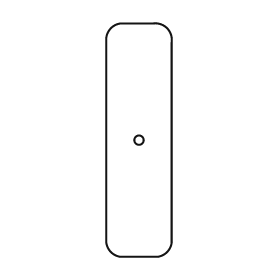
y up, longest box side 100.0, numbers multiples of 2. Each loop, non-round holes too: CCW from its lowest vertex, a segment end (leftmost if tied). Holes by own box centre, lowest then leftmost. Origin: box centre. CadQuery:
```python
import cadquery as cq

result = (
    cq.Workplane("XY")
    .moveTo(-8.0, -50.0)
    .lineTo(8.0, -50.0)
    .threePointArc((12.0, -48.0), (14.0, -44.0))
    .lineTo(14.0, 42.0)
    .threePointArc((12.0, 48.0), (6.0, 50.0))
    .lineTo(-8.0, 50.0)
    .threePointArc((-12.0, 48.0), (-14.0, 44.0))
    .lineTo(-14.0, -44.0)
    .threePointArc((-12.0, -48.0), (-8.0, -50.0))
    .close()
    .moveTo(0.0, 0.0)
    .circle(2.0)
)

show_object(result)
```